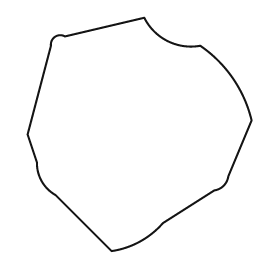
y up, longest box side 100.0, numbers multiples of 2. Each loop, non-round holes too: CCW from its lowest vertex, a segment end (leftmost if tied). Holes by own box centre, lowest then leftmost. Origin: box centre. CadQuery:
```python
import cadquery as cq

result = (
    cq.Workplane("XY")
    .moveTo(-12.0, -50.0)
    .threePointArc((0.0, -46.0), (10.0, -38.0))
    .lineTo(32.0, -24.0)
    .threePointArc((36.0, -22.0), (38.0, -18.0))
    .lineTo(48.0, 6.0)
    .threePointArc((40.0, 24.0), (26.0, 38.0))
    .threePointArc((12.0, 40.0), (2.0, 50.0))
    .lineTo(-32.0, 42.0)
    .threePointArc((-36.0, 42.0), (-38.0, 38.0))
    .lineTo(-48.0, 0.0)
    .lineTo(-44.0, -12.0)
    .threePointArc((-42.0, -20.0), (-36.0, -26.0))
    .close()
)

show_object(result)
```